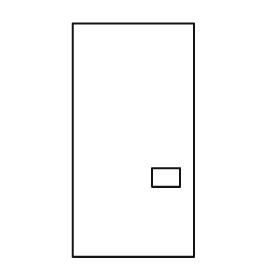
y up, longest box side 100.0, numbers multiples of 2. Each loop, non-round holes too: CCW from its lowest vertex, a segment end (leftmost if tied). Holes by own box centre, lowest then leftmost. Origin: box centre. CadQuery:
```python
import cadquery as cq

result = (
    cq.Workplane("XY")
    .moveTo(-26.0, -50.0)
    .lineTo(26.0, -50.0)
    .lineTo(26.0, 50.0)
    .lineTo(-26.0, 50.0)
    .close()
    .moveTo(8.0, -20.0)
    .lineTo(20.0, -20.0)
    .lineTo(20.0, -12.0)
    .lineTo(8.0, -12.0)
    .close()
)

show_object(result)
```